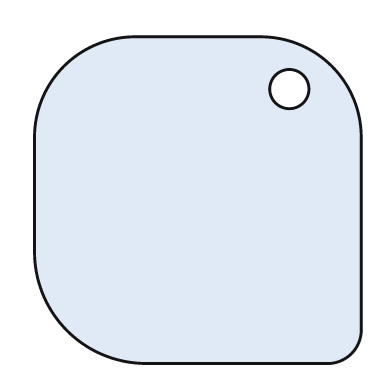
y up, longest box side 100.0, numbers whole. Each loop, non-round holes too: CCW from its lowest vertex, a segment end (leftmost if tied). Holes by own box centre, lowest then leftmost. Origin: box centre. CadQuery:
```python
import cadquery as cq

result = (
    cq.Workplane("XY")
    .moveTo(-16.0, -50.0)
    .lineTo(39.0, -50.0)
    .threePointArc((47.0, -47.0), (50.0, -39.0))
    .lineTo(50.0, 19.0)
    .threePointArc((41.0, 41.0), (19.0, 50.0))
    .lineTo(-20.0, 50.0)
    .threePointArc((-41.0, 41.0), (-50.0, 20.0))
    .lineTo(-50.0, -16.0)
    .threePointArc((-40.0, -40.0), (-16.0, -50.0))
    .close()
    .moveTo(28.0, 34.0)
    .circle(6.0)
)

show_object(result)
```